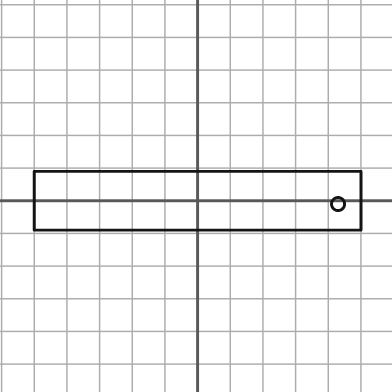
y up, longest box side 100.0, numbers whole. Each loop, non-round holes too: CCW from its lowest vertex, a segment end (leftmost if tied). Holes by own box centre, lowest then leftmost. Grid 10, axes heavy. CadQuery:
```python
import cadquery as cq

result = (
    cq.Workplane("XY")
    .moveTo(-50.0, -9.0)
    .lineTo(50.0, -9.0)
    .lineTo(50.0, 9.0)
    .lineTo(-50.0, 9.0)
    .close()
    .moveTo(43.0, -1.0)
    .circle(2.0)
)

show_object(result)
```